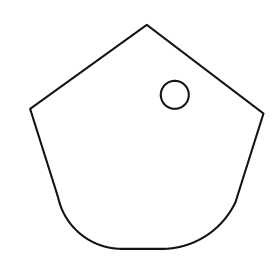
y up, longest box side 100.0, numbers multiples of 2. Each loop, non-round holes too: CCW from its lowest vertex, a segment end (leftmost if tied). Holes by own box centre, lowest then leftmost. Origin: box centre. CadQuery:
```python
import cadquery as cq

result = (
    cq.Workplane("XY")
    .moveTo(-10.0, -48.0)
    .lineTo(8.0, -48.0)
    .threePointArc((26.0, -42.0), (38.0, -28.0))
    .lineTo(50.0, 10.0)
    .lineTo(0.0, 48.0)
    .lineTo(-50.0, 12.0)
    .lineTo(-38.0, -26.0)
    .threePointArc((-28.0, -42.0), (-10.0, -48.0))
    .close()
    .moveTo(12.0, 18.0)
    .circle(6.0)
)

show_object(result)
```